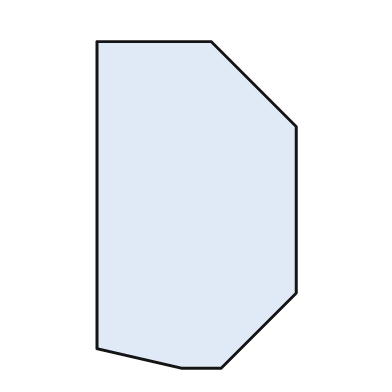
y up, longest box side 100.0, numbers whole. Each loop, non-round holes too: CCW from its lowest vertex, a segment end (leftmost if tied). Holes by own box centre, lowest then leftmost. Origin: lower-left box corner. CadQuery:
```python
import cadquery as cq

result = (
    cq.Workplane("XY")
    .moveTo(26.0, 0.0)
    .lineTo(38.0, 0.0)
    .lineTo(61.0, 23.0)
    .lineTo(61.0, 74.0)
    .lineTo(35.0, 100.0)
    .lineTo(0.0, 100.0)
    .lineTo(0.0, 6.0)
    .close()
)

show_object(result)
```